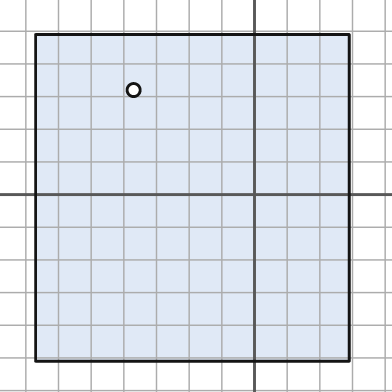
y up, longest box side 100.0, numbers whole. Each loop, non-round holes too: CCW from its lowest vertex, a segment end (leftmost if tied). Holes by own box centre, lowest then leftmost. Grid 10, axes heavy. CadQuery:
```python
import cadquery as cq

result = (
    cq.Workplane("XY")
    .moveTo(-67.0, -51.0)
    .lineTo(29.0, -51.0)
    .lineTo(29.0, 49.0)
    .lineTo(-67.0, 49.0)
    .close()
    .moveTo(-37.0, 32.0)
    .circle(2.0)
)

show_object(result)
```